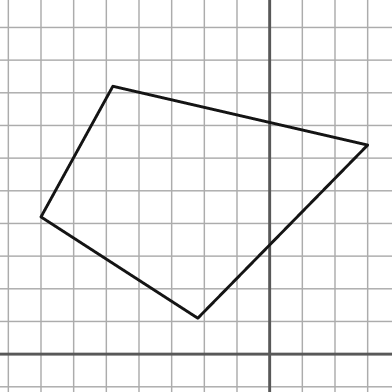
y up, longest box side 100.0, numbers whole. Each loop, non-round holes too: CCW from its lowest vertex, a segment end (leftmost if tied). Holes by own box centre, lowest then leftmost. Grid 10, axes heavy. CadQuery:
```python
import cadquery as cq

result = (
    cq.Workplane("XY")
    .moveTo(-22.0, 11.0)
    .lineTo(30.0, 64.0)
    .lineTo(-48.0, 82.0)
    .lineTo(-70.0, 42.0)
    .close()
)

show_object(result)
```